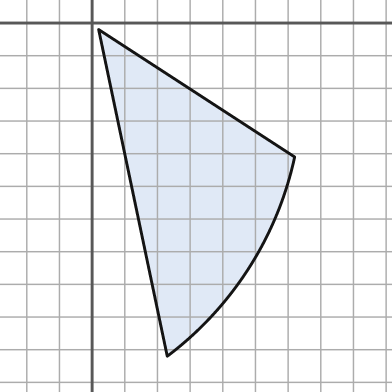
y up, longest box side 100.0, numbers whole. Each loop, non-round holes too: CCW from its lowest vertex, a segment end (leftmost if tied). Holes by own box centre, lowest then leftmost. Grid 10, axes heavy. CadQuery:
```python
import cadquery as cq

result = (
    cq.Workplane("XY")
    .moveTo(23.0, -102.0)
    .threePointArc((48.0, -75.0), (62.0, -41.0))
    .lineTo(2.0, -2.0)
    .close()
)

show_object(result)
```